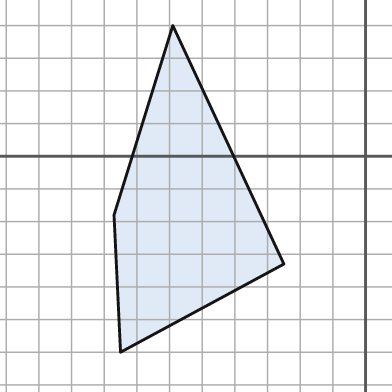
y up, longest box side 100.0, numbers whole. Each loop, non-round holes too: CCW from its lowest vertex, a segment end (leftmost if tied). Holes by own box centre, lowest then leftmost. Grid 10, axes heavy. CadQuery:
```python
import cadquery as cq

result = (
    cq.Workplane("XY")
    .moveTo(-75.0, -60.0)
    .lineTo(-25.0, -33.0)
    .lineTo(-59.0, 40.0)
    .lineTo(-77.0, -18.0)
    .close()
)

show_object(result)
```